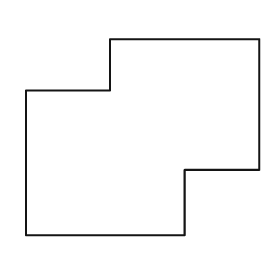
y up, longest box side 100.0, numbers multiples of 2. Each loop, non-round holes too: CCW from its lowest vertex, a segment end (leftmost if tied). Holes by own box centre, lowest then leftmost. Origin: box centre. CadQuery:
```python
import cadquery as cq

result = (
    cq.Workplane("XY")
    .moveTo(-50.0, -42.0)
    .lineTo(18.0, -42.0)
    .lineTo(18.0, -14.0)
    .lineTo(50.0, -14.0)
    .lineTo(50.0, 42.0)
    .lineTo(-14.0, 42.0)
    .lineTo(-14.0, 20.0)
    .lineTo(-50.0, 20.0)
    .close()
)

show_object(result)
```